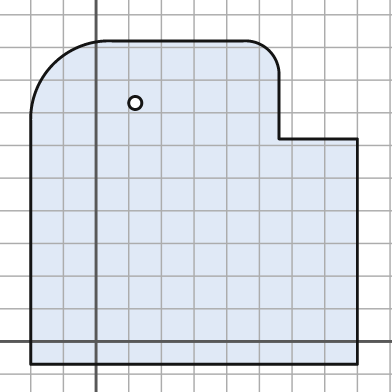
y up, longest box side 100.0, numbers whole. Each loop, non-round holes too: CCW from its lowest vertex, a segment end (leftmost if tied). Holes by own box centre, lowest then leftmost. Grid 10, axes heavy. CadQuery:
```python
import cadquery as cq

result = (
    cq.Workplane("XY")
    .moveTo(-20.0, -7.0)
    .lineTo(80.0, -7.0)
    .lineTo(80.0, 62.0)
    .lineTo(56.0, 62.0)
    .lineTo(56.0, 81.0)
    .threePointArc((53.0, 89.0), (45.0, 92.0))
    .lineTo(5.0, 92.0)
    .threePointArc((-13.0, 85.0), (-20.0, 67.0))
    .close()
    .moveTo(12.0, 73.0)
    .circle(2.0)
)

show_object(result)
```